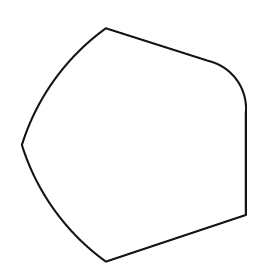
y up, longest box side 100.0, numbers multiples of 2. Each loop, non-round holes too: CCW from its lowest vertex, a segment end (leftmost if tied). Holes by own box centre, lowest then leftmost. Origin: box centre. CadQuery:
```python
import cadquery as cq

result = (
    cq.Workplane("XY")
    .moveTo(-12.0, -50.0)
    .lineTo(48.0, -30.0)
    .lineTo(48.0, 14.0)
    .threePointArc((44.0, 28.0), (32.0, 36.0))
    .lineTo(-12.0, 50.0)
    .threePointArc((-34.0, 28.0), (-48.0, 0.0))
    .threePointArc((-34.0, -28.0), (-12.0, -50.0))
    .close()
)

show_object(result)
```